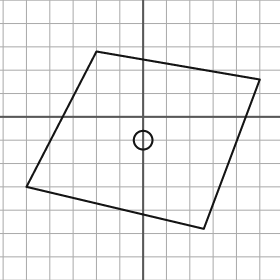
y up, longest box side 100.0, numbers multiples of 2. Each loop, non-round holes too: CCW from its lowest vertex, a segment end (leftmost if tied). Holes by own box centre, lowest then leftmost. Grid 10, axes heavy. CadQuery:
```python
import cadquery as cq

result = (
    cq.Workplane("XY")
    .moveTo(26.0, -48.0)
    .lineTo(50.0, 16.0)
    .lineTo(-20.0, 28.0)
    .lineTo(-50.0, -30.0)
    .close()
    .moveTo(0.0, -10.0)
    .circle(4.0)
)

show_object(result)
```